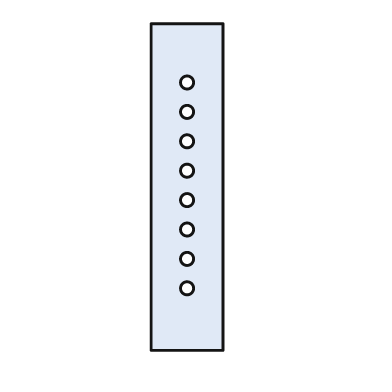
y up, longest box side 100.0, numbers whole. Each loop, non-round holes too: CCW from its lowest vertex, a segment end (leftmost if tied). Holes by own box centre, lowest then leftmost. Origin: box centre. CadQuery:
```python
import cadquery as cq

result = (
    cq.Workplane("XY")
    .moveTo(-11.0, -50.0)
    .lineTo(11.0, -50.0)
    .lineTo(11.0, 50.0)
    .lineTo(-11.0, 50.0)
    .close()
    .moveTo(0.0, -31.0)
    .circle(2.0)
    .moveTo(0.0, -22.0)
    .circle(2.0)
    .moveTo(0.0, -13.0)
    .circle(2.0)
    .moveTo(0.0, -4.0)
    .circle(2.0)
    .moveTo(0.0, 5.0)
    .circle(2.0)
    .moveTo(0.0, 14.0)
    .circle(2.0)
    .moveTo(0.0, 23.0)
    .circle(2.0)
    .moveTo(0.0, 32.0)
    .circle(2.0)
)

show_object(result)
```